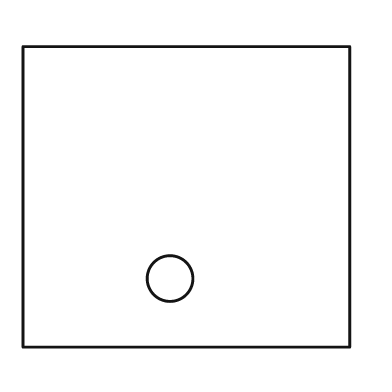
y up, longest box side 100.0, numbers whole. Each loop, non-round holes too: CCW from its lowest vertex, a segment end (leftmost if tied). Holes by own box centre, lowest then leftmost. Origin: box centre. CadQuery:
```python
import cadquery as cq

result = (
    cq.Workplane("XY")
    .moveTo(-50.0, -46.0)
    .lineTo(50.0, -46.0)
    .lineTo(50.0, 46.0)
    .lineTo(-50.0, 46.0)
    .close()
    .moveTo(-5.0, -25.0)
    .circle(7.0)
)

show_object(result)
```